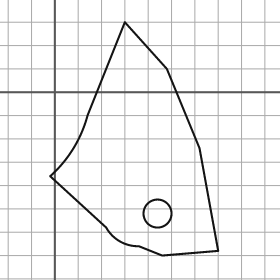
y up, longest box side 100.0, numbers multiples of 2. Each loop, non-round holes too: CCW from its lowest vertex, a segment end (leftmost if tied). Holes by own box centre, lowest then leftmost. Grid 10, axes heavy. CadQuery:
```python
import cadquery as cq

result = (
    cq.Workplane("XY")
    .moveTo(46.0, -70.0)
    .lineTo(70.0, -68.0)
    .lineTo(62.0, -24.0)
    .lineTo(48.0, 10.0)
    .lineTo(30.0, 30.0)
    .lineTo(14.0, -10.0)
    .threePointArc((8.0, -24.0), (-2.0, -36.0))
    .lineTo(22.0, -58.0)
    .threePointArc((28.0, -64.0), (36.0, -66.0))
    .close()
    .moveTo(44.0, -52.0)
    .circle(6.0)
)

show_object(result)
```